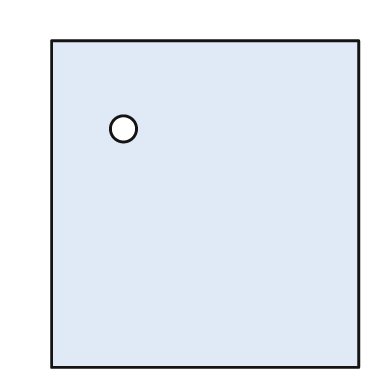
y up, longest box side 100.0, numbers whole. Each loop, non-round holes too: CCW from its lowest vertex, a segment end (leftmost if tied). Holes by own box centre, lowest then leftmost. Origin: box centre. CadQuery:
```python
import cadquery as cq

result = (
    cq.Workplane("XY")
    .moveTo(-47.0, -50.0)
    .lineTo(47.0, -50.0)
    .lineTo(47.0, 50.0)
    .lineTo(-47.0, 50.0)
    .close()
    .moveTo(-25.0, 23.0)
    .circle(4.0)
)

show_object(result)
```